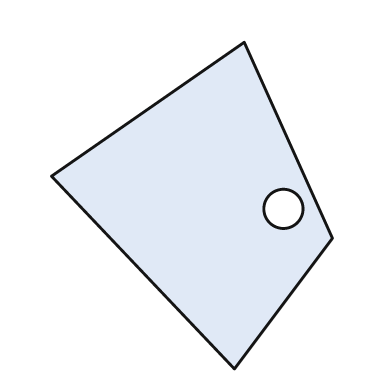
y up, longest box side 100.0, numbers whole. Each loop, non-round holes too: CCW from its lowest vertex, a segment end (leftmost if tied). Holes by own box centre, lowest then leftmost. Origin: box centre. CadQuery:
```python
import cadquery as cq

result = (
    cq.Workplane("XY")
    .moveTo(13.0, -50.0)
    .lineTo(43.0, -10.0)
    .lineTo(16.0, 50.0)
    .lineTo(-43.0, 9.0)
    .close()
    .moveTo(28.0, -1.0)
    .circle(6.0)
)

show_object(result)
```